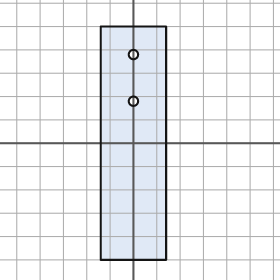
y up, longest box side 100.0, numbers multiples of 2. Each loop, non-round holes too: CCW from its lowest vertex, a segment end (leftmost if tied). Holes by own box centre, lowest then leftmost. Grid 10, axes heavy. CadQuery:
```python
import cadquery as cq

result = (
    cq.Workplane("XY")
    .moveTo(-14.0, -50.0)
    .lineTo(14.0, -50.0)
    .lineTo(14.0, 50.0)
    .lineTo(-14.0, 50.0)
    .close()
    .moveTo(0.0, 18.0)
    .circle(2.0)
    .moveTo(0.0, 38.0)
    .circle(2.0)
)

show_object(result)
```